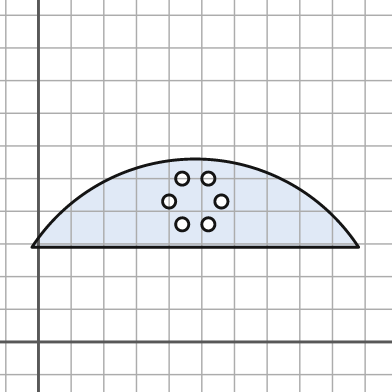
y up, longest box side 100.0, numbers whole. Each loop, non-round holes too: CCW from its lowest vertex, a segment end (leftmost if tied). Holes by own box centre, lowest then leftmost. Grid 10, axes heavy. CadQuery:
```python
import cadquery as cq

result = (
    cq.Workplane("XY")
    .moveTo(-2.0, 29.0)
    .lineTo(98.0, 29.0)
    .threePointArc((48.0, 56.0), (-2.0, 29.0))
    .close()
    .moveTo(44.0, 36.0)
    .circle(2.0)
    .moveTo(52.0, 36.0)
    .circle(2.0)
    .moveTo(40.0, 43.0)
    .circle(2.0)
    .moveTo(56.0, 43.0)
    .circle(2.0)
    .moveTo(44.0, 50.0)
    .circle(2.0)
    .moveTo(52.0, 50.0)
    .circle(2.0)
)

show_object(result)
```